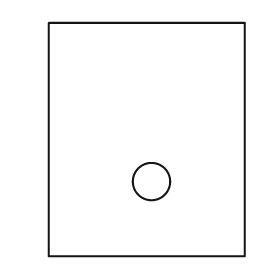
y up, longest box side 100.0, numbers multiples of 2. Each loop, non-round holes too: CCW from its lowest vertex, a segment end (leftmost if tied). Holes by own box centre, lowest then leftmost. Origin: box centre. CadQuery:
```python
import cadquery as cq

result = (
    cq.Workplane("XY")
    .moveTo(-42.0, -50.0)
    .lineTo(42.0, -50.0)
    .lineTo(42.0, 50.0)
    .lineTo(-42.0, 50.0)
    .close()
    .moveTo(2.0, -18.0)
    .circle(8.0)
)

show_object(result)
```